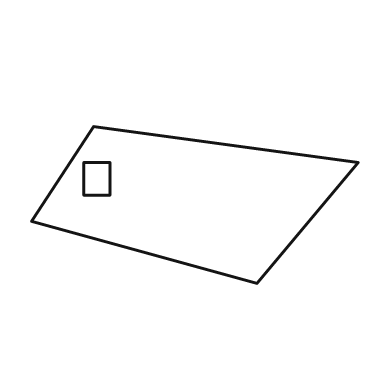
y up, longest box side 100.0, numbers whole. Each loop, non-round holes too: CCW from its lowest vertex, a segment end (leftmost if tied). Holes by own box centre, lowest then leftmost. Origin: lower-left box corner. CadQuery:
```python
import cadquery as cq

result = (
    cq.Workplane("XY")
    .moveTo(69.0, 0.0)
    .lineTo(100.0, 37.0)
    .lineTo(19.0, 48.0)
    .lineTo(0.0, 19.0)
    .close()
    .moveTo(16.0, 27.0)
    .lineTo(24.0, 27.0)
    .lineTo(24.0, 37.0)
    .lineTo(16.0, 37.0)
    .close()
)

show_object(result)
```